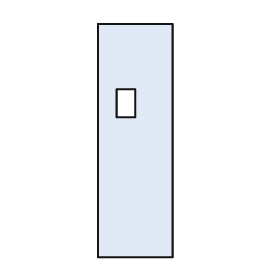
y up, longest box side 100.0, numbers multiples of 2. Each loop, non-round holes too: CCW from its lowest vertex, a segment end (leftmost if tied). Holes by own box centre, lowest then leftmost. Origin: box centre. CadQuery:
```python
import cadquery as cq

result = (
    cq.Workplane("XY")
    .moveTo(-16.0, -50.0)
    .lineTo(16.0, -50.0)
    .lineTo(16.0, 50.0)
    .lineTo(-16.0, 50.0)
    .close()
    .moveTo(-8.0, 10.0)
    .lineTo(0.0, 10.0)
    .lineTo(0.0, 22.0)
    .lineTo(-8.0, 22.0)
    .close()
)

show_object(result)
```